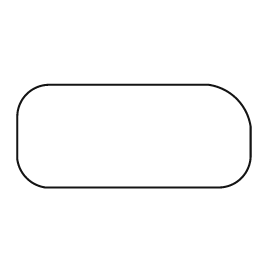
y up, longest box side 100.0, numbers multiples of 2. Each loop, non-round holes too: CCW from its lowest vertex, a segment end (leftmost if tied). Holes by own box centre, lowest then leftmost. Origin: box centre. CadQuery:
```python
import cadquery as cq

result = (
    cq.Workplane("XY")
    .moveTo(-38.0, -22.0)
    .lineTo(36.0, -22.0)
    .threePointArc((46.0, -18.0), (50.0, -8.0))
    .lineTo(50.0, 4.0)
    .threePointArc((44.0, 16.0), (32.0, 22.0))
    .lineTo(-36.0, 22.0)
    .threePointArc((-46.0, 18.0), (-50.0, 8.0))
    .lineTo(-50.0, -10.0)
    .threePointArc((-46.0, -18.0), (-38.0, -22.0))
    .close()
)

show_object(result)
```